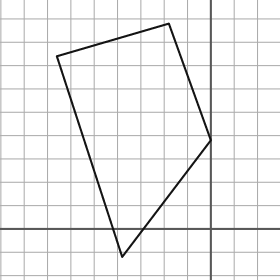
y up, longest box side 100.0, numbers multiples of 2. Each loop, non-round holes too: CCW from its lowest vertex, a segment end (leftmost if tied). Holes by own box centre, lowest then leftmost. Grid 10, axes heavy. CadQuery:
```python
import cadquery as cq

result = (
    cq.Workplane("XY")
    .moveTo(-38.0, -12.0)
    .lineTo(0.0, 38.0)
    .lineTo(-18.0, 88.0)
    .lineTo(-66.0, 74.0)
    .close()
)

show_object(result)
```